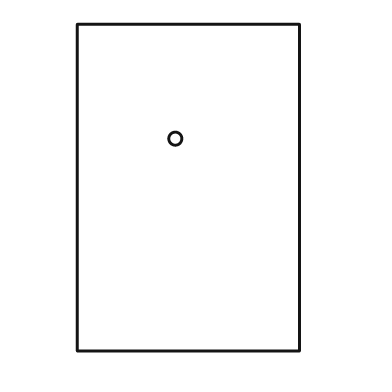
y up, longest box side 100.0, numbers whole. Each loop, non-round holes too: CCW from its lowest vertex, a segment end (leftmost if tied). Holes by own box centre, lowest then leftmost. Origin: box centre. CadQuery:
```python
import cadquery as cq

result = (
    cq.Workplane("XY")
    .moveTo(-34.0, -50.0)
    .lineTo(34.0, -50.0)
    .lineTo(34.0, 50.0)
    .lineTo(-34.0, 50.0)
    .close()
    .moveTo(-4.0, 15.0)
    .circle(2.0)
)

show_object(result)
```